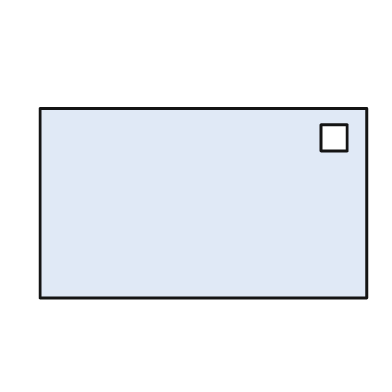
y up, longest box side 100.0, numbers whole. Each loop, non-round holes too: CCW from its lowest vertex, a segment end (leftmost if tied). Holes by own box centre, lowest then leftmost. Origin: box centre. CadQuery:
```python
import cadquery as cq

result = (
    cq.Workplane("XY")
    .moveTo(-50.0, -29.0)
    .lineTo(50.0, -29.0)
    .lineTo(50.0, 29.0)
    .lineTo(-50.0, 29.0)
    .close()
    .moveTo(36.0, 16.0)
    .lineTo(44.0, 16.0)
    .lineTo(44.0, 24.0)
    .lineTo(36.0, 24.0)
    .close()
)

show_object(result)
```